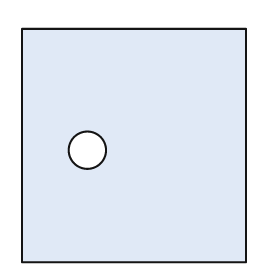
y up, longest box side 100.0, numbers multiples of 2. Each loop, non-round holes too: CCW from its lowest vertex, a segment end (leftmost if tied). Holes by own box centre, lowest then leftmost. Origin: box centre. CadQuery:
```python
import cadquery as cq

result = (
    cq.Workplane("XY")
    .moveTo(-48.0, -50.0)
    .lineTo(48.0, -50.0)
    .lineTo(48.0, 50.0)
    .lineTo(-48.0, 50.0)
    .close()
    .moveTo(-20.0, -2.0)
    .circle(8.0)
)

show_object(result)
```